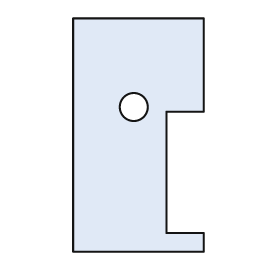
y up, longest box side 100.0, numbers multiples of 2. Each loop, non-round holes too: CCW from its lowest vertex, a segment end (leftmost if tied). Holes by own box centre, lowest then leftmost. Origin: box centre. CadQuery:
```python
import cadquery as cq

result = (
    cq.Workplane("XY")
    .moveTo(-28.0, -50.0)
    .lineTo(28.0, -50.0)
    .lineTo(28.0, -42.0)
    .lineTo(12.0, -42.0)
    .lineTo(12.0, 10.0)
    .lineTo(28.0, 10.0)
    .lineTo(28.0, 50.0)
    .lineTo(-28.0, 50.0)
    .close()
    .moveTo(-2.0, 12.0)
    .circle(6.0)
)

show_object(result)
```